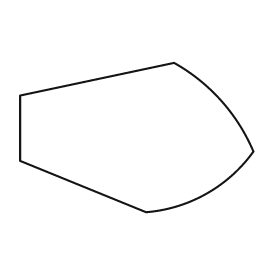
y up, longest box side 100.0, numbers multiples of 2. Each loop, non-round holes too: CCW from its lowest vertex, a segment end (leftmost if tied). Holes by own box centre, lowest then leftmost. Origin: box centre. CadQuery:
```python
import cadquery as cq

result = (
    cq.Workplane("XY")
    .moveTo(4.0, -32.0)
    .threePointArc((30.0, -24.0), (50.0, -6.0))
    .threePointArc((36.0, 16.0), (16.0, 32.0))
    .lineTo(-50.0, 18.0)
    .lineTo(-50.0, -10.0)
    .close()
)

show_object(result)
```